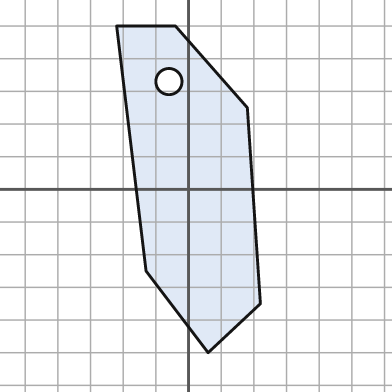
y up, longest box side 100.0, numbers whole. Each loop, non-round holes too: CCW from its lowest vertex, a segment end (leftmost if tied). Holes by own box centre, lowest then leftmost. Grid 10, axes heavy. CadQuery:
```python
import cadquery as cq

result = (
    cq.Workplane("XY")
    .moveTo(6.0, -50.0)
    .lineTo(22.0, -35.0)
    .lineTo(18.0, 25.0)
    .lineTo(-4.0, 50.0)
    .lineTo(-22.0, 50.0)
    .lineTo(-13.0, -25.0)
    .close()
    .moveTo(-6.0, 33.0)
    .circle(4.0)
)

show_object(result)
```